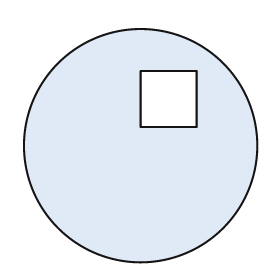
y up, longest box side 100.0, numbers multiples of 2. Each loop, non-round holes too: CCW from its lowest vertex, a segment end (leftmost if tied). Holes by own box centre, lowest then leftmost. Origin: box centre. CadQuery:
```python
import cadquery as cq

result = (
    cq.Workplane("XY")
    .moveTo(0.0, 0.0)
    .circle(50.0)
    .moveTo(0.0, 8.0)
    .lineTo(24.0, 8.0)
    .lineTo(24.0, 32.0)
    .lineTo(0.0, 32.0)
    .close()
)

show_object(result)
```